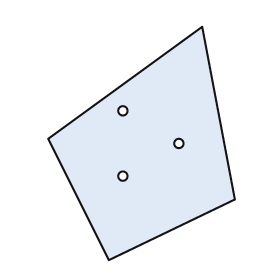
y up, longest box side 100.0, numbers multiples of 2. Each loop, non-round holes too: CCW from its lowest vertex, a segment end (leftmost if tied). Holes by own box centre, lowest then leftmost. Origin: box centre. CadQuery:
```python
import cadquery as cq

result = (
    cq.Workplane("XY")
    .moveTo(-14.0, -50.0)
    .lineTo(40.0, -24.0)
    .lineTo(26.0, 50.0)
    .lineTo(-40.0, 2.0)
    .close()
    .moveTo(-8.0, -14.0)
    .circle(2.0)
    .moveTo(16.0, 0.0)
    .circle(2.0)
    .moveTo(-8.0, 14.0)
    .circle(2.0)
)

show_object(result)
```